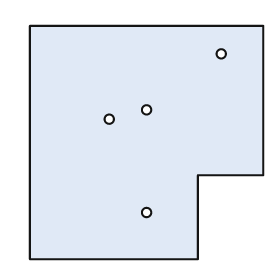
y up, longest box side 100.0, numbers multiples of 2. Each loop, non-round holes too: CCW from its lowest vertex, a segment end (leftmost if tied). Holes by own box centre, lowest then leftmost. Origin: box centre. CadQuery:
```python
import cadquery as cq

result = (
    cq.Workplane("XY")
    .moveTo(-50.0, -50.0)
    .lineTo(22.0, -50.0)
    .lineTo(22.0, -14.0)
    .lineTo(50.0, -14.0)
    .lineTo(50.0, 50.0)
    .lineTo(-50.0, 50.0)
    .close()
    .moveTo(0.0, -30.0)
    .circle(2.0)
    .moveTo(-16.0, 10.0)
    .circle(2.0)
    .moveTo(0.0, 14.0)
    .circle(2.0)
    .moveTo(32.0, 38.0)
    .circle(2.0)
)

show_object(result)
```